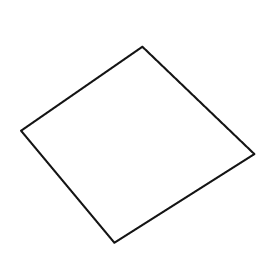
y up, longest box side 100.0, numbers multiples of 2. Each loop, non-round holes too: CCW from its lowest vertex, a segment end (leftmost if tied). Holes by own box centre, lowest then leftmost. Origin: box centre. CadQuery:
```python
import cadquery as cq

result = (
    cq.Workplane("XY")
    .moveTo(-10.0, -42.0)
    .lineTo(50.0, -4.0)
    .lineTo(2.0, 42.0)
    .lineTo(-50.0, 6.0)
    .close()
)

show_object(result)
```